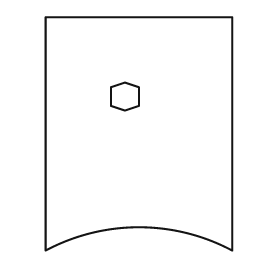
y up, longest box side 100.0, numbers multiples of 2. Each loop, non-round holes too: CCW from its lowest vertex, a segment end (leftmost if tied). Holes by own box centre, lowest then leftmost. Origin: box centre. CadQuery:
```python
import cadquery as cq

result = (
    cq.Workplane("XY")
    .moveTo(-40.0, -50.0)
    .threePointArc((0.0, -40.0), (40.0, -50.0))
    .lineTo(40.0, 50.0)
    .lineTo(-40.0, 50.0)
    .close()
    .moveTo(-6.0, 10.0)
    .lineTo(0.0, 12.0)
    .lineTo(0.0, 20.0)
    .lineTo(-6.0, 22.0)
    .lineTo(-12.0, 20.0)
    .lineTo(-12.0, 12.0)
    .close()
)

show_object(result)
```